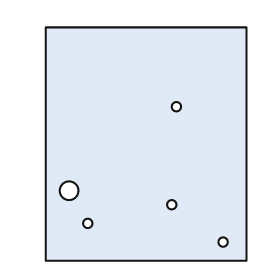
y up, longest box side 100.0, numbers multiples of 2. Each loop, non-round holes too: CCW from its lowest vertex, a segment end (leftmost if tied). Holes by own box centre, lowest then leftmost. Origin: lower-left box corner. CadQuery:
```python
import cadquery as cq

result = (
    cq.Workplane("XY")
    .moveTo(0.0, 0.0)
    .lineTo(86.0, 0.0)
    .lineTo(86.0, 100.0)
    .lineTo(0.0, 100.0)
    .close()
    .moveTo(76.0, 8.0)
    .circle(2.0)
    .moveTo(18.0, 16.0)
    .circle(2.0)
    .moveTo(54.0, 24.0)
    .circle(2.0)
    .moveTo(10.0, 30.0)
    .circle(4.0)
    .moveTo(56.0, 66.0)
    .circle(2.0)
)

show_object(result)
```